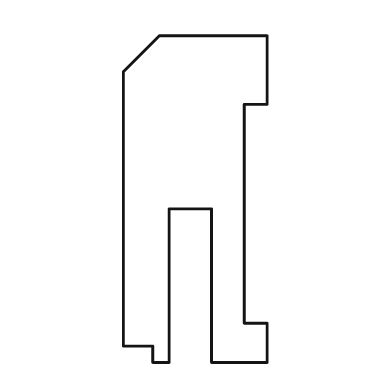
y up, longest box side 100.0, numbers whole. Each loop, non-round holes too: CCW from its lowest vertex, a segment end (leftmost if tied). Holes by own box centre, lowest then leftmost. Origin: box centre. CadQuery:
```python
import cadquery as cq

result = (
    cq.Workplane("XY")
    .moveTo(-13.0, -50.0)
    .lineTo(-8.0, -50.0)
    .lineTo(-8.0, -3.0)
    .lineTo(5.0, -3.0)
    .lineTo(5.0, -50.0)
    .lineTo(22.0, -50.0)
    .lineTo(22.0, -38.0)
    .lineTo(15.0, -38.0)
    .lineTo(15.0, 29.0)
    .lineTo(22.0, 29.0)
    .lineTo(22.0, 50.0)
    .lineTo(-11.0, 50.0)
    .lineTo(-22.0, 39.0)
    .lineTo(-22.0, -45.0)
    .lineTo(-13.0, -45.0)
    .close()
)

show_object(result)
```